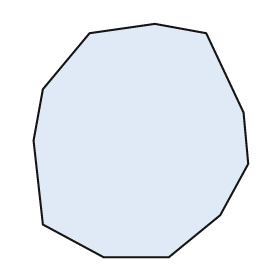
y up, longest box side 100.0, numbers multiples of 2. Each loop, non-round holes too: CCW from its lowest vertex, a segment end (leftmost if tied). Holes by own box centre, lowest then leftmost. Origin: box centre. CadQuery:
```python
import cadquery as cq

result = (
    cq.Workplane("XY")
    .moveTo(-16.0, -50.0)
    .lineTo(12.0, -50.0)
    .lineTo(34.0, -32.0)
    .lineTo(46.0, -10.0)
    .lineTo(44.0, 12.0)
    .lineTo(28.0, 46.0)
    .lineTo(6.0, 50.0)
    .lineTo(-22.0, 46.0)
    .lineTo(-42.0, 22.0)
    .lineTo(-46.0, 0.0)
    .lineTo(-42.0, -36.0)
    .close()
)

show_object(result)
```